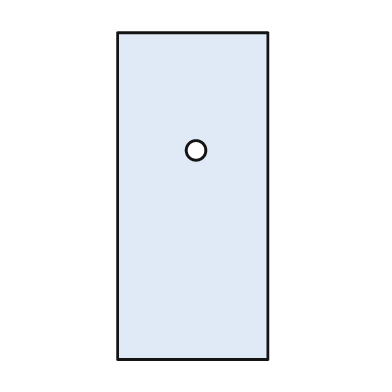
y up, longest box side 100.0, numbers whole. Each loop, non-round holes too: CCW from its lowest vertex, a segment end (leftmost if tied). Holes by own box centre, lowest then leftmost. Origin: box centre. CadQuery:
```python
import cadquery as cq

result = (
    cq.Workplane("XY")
    .moveTo(-23.0, -50.0)
    .lineTo(23.0, -50.0)
    .lineTo(23.0, 50.0)
    .lineTo(-23.0, 50.0)
    .close()
    .moveTo(1.0, 14.0)
    .circle(3.0)
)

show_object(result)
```